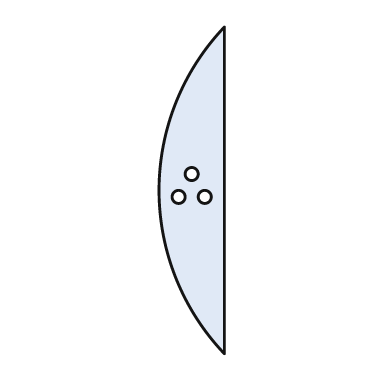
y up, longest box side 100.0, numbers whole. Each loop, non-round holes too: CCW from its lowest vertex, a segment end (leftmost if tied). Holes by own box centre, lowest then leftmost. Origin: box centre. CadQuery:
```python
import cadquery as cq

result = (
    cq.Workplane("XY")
    .moveTo(10.0, -50.0)
    .lineTo(10.0, 50.0)
    .threePointArc((-10.0, 0.0), (10.0, -50.0))
    .close()
    .moveTo(-4.0, -2.0)
    .circle(2.0)
    .moveTo(4.0, -2.0)
    .circle(2.0)
    .moveTo(0.0, 5.0)
    .circle(2.0)
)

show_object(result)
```